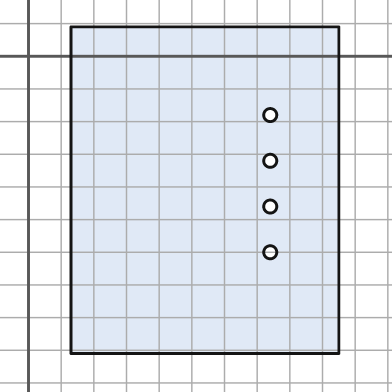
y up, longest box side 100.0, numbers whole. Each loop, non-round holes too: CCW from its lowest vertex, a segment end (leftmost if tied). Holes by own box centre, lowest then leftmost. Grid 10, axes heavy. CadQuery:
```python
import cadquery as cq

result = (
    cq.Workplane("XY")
    .moveTo(13.0, -91.0)
    .lineTo(95.0, -91.0)
    .lineTo(95.0, 9.0)
    .lineTo(13.0, 9.0)
    .close()
    .moveTo(74.0, -60.0)
    .circle(2.0)
    .moveTo(74.0, -46.0)
    .circle(2.0)
    .moveTo(74.0, -32.0)
    .circle(2.0)
    .moveTo(74.0, -18.0)
    .circle(2.0)
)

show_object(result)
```